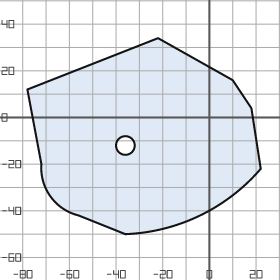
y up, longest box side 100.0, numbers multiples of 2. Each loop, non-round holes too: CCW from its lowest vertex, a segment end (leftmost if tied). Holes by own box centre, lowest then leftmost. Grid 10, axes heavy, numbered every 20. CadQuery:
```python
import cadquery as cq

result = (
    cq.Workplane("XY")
    .moveTo(-36.0, -50.0)
    .threePointArc((-4.0, -42.0), (22.0, -22.0))
    .lineTo(18.0, 4.0)
    .lineTo(10.0, 16.0)
    .lineTo(-22.0, 34.0)
    .lineTo(-78.0, 12.0)
    .lineTo(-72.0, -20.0)
    .threePointArc((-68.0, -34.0), (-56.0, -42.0))
    .close()
    .moveTo(-36.0, -12.0)
    .circle(4.0)
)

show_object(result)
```